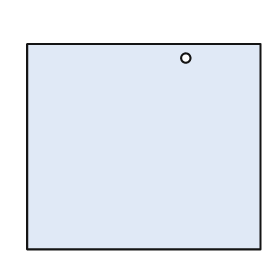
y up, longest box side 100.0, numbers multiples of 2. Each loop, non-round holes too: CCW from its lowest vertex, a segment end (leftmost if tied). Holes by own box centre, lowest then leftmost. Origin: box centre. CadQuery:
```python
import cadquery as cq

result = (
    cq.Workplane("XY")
    .moveTo(-50.0, -44.0)
    .lineTo(50.0, -44.0)
    .lineTo(50.0, 44.0)
    .lineTo(-50.0, 44.0)
    .close()
    .moveTo(18.0, 38.0)
    .circle(2.0)
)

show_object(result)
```